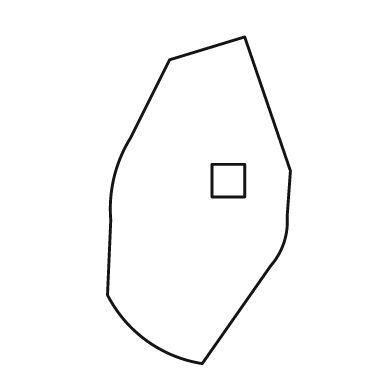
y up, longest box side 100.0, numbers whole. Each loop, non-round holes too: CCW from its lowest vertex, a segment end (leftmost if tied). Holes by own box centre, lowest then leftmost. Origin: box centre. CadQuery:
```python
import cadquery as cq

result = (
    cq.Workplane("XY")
    .moveTo(1.0, -50.0)
    .lineTo(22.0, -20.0)
    .threePointArc((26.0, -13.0), (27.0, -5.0))
    .lineTo(28.0, 9.0)
    .lineTo(14.0, 50.0)
    .lineTo(-9.0, 43.0)
    .lineTo(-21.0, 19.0)
    .threePointArc((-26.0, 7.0), (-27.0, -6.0))
    .lineTo(-28.0, -29.0)
    .threePointArc((-16.0, -43.0), (1.0, -50.0))
    .close()
    .moveTo(4.0, 1.0)
    .lineTo(14.0, 1.0)
    .lineTo(14.0, 11.0)
    .lineTo(4.0, 11.0)
    .close()
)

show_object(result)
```